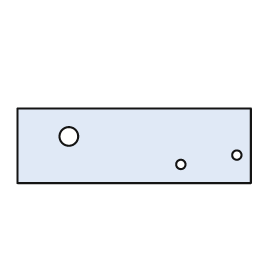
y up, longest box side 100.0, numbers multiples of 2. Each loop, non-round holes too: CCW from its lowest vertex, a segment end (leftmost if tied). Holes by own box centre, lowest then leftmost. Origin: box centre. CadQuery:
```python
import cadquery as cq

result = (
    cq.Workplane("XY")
    .moveTo(-50.0, -16.0)
    .lineTo(50.0, -16.0)
    .lineTo(50.0, 16.0)
    .lineTo(-50.0, 16.0)
    .close()
    .moveTo(20.0, -8.0)
    .circle(2.0)
    .moveTo(44.0, -4.0)
    .circle(2.0)
    .moveTo(-28.0, 4.0)
    .circle(4.0)
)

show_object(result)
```